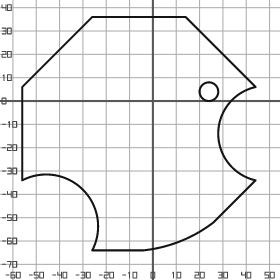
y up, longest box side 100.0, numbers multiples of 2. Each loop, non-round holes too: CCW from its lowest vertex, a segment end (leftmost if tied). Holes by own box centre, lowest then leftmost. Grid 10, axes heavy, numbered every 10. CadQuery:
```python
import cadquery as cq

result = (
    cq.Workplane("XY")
    .moveTo(-26.0, -64.0)
    .lineTo(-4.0, -64.0)
    .threePointArc((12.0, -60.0), (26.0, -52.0))
    .lineTo(44.0, -34.0)
    .threePointArc((28.0, -14.0), (44.0, 6.0))
    .lineTo(14.0, 36.0)
    .lineTo(-26.0, 36.0)
    .lineTo(-56.0, 6.0)
    .lineTo(-56.0, -34.0)
    .threePointArc((-30.0, -38.0), (-26.0, -64.0))
    .close()
    .moveTo(24.0, 4.0)
    .circle(4.0)
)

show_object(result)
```